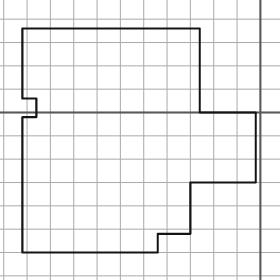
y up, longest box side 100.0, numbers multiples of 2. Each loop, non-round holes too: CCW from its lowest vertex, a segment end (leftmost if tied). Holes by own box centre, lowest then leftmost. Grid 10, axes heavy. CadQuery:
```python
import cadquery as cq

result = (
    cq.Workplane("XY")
    .moveTo(-102.0, -60.0)
    .lineTo(-44.0, -60.0)
    .lineTo(-44.0, -52.0)
    .lineTo(-30.0, -52.0)
    .lineTo(-30.0, -30.0)
    .lineTo(-2.0, -30.0)
    .lineTo(-2.0, 0.0)
    .lineTo(-26.0, 0.0)
    .lineTo(-26.0, 36.0)
    .lineTo(-102.0, 36.0)
    .lineTo(-102.0, 6.0)
    .lineTo(-96.0, 6.0)
    .lineTo(-96.0, -2.0)
    .lineTo(-102.0, -2.0)
    .close()
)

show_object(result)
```